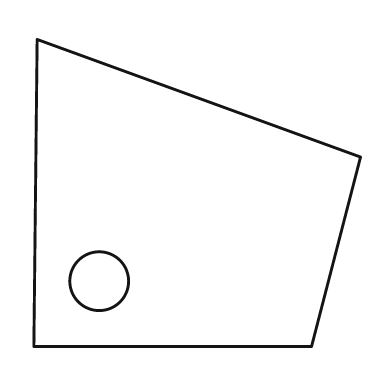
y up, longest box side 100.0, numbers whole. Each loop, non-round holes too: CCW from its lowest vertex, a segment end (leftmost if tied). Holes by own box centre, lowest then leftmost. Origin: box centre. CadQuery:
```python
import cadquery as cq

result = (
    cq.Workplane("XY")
    .moveTo(-50.0, -47.0)
    .lineTo(35.0, -47.0)
    .lineTo(50.0, 11.0)
    .lineTo(-49.0, 47.0)
    .close()
    .moveTo(-30.0, -27.0)
    .circle(9.0)
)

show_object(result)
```